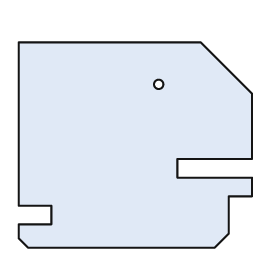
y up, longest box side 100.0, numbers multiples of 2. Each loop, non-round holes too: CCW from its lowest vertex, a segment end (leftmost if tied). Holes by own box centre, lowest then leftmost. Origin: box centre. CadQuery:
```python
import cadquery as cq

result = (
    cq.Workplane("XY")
    .moveTo(-46.0, -44.0)
    .lineTo(34.0, -44.0)
    .lineTo(40.0, -38.0)
    .lineTo(40.0, -22.0)
    .lineTo(50.0, -22.0)
    .lineTo(50.0, -14.0)
    .lineTo(18.0, -14.0)
    .lineTo(18.0, -6.0)
    .lineTo(50.0, -6.0)
    .lineTo(50.0, 22.0)
    .lineTo(28.0, 44.0)
    .lineTo(-50.0, 44.0)
    .lineTo(-50.0, -26.0)
    .lineTo(-36.0, -26.0)
    .lineTo(-36.0, -34.0)
    .lineTo(-50.0, -34.0)
    .lineTo(-50.0, -40.0)
    .close()
    .moveTo(10.0, 26.0)
    .circle(2.0)
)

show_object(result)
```